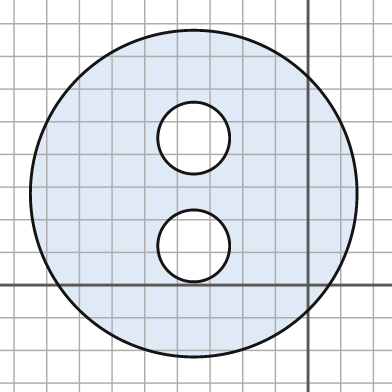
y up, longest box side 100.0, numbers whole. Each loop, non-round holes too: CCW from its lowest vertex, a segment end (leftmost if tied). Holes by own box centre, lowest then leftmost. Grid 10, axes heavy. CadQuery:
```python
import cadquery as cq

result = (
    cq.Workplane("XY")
    .moveTo(-35.0, 28.0)
    .circle(50.0)
    .moveTo(-35.0, 12.0)
    .circle(11.0)
    .moveTo(-35.0, 45.0)
    .circle(11.0)
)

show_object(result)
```